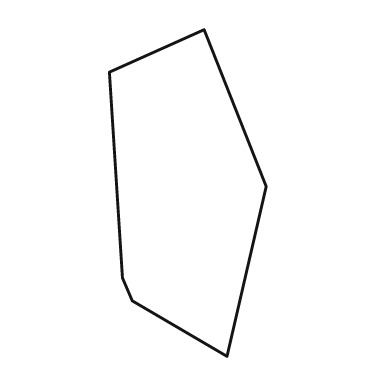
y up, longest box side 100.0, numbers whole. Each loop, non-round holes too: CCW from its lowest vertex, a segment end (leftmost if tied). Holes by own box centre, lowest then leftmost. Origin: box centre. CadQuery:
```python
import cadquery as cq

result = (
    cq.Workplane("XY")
    .moveTo(12.0, -50.0)
    .lineTo(24.0, 2.0)
    .lineTo(5.0, 50.0)
    .lineTo(-24.0, 37.0)
    .lineTo(-20.0, -26.0)
    .lineTo(-17.0, -33.0)
    .close()
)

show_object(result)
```